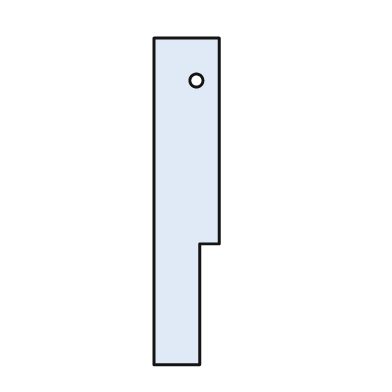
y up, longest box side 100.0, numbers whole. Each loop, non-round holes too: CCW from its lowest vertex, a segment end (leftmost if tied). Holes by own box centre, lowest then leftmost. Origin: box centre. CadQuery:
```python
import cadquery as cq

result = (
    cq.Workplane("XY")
    .moveTo(-10.0, -50.0)
    .lineTo(4.0, -50.0)
    .lineTo(4.0, -13.0)
    .lineTo(10.0, -13.0)
    .lineTo(10.0, 50.0)
    .lineTo(-10.0, 50.0)
    .close()
    .moveTo(3.0, 37.0)
    .circle(2.0)
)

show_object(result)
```